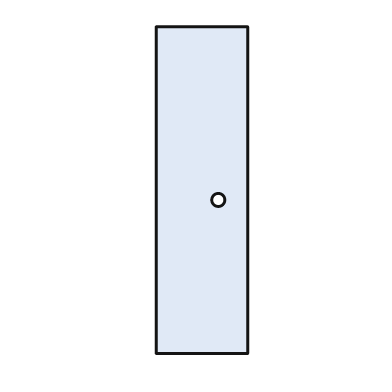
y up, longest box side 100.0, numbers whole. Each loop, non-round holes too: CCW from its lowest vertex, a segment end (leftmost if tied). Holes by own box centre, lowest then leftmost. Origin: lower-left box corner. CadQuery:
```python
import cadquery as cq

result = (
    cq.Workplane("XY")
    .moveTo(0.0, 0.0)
    .lineTo(28.0, 0.0)
    .lineTo(28.0, 100.0)
    .lineTo(0.0, 100.0)
    .close()
    .moveTo(19.0, 47.0)
    .circle(2.0)
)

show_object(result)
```